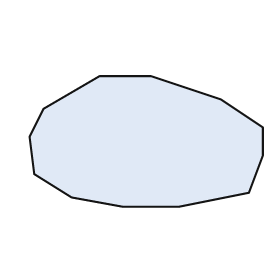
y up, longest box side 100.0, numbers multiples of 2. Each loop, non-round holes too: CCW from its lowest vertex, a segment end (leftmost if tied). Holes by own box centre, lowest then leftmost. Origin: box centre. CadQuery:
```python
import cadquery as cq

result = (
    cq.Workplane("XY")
    .moveTo(-10.0, -28.0)
    .lineTo(14.0, -28.0)
    .lineTo(44.0, -22.0)
    .lineTo(50.0, -6.0)
    .lineTo(50.0, 6.0)
    .lineTo(32.0, 18.0)
    .lineTo(2.0, 28.0)
    .lineTo(-20.0, 28.0)
    .lineTo(-44.0, 14.0)
    .lineTo(-50.0, 2.0)
    .lineTo(-48.0, -14.0)
    .lineTo(-32.0, -24.0)
    .close()
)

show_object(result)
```